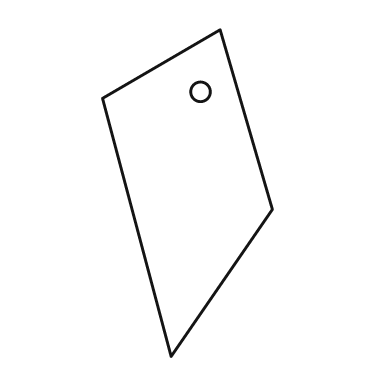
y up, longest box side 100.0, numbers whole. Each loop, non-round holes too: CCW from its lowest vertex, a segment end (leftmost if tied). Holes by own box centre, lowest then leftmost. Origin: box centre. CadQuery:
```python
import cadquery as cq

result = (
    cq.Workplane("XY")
    .moveTo(-5.0, -50.0)
    .lineTo(26.0, -5.0)
    .lineTo(10.0, 50.0)
    .lineTo(-26.0, 29.0)
    .close()
    .moveTo(4.0, 31.0)
    .circle(3.0)
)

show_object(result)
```